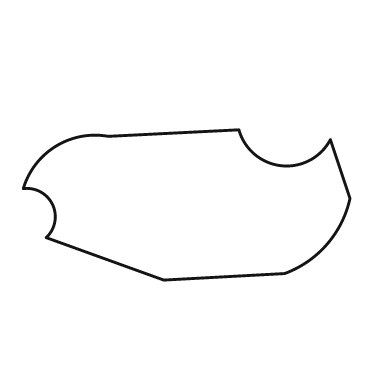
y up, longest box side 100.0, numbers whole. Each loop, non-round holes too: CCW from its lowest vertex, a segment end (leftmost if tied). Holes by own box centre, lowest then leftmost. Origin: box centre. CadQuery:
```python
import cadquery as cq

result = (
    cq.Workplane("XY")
    .moveTo(-7.0, -23.0)
    .lineTo(30.0, -21.0)
    .threePointArc((43.0, -12.0), (50.0, 2.0))
    .lineTo(44.0, 20.0)
    .threePointArc((29.0, 12.0), (16.0, 23.0))
    .lineTo(-24.0, 21.0)
    .threePointArc((-40.0, 18.0), (-50.0, 5.0))
    .threePointArc((-41.0, 0.0), (-43.0, -10.0))
    .close()
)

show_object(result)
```